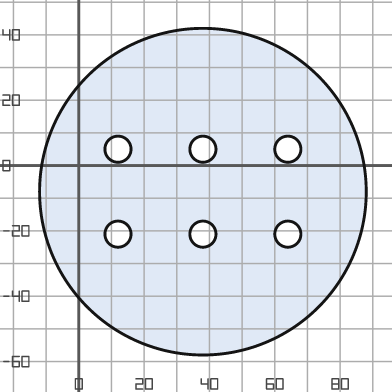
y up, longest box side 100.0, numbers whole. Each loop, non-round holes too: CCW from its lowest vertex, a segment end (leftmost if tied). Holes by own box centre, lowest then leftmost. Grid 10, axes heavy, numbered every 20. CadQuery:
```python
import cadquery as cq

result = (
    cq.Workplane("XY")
    .moveTo(38.0, -8.0)
    .circle(50.0)
    .moveTo(12.0, -21.0)
    .circle(4.0)
    .moveTo(38.0, -21.0)
    .circle(4.0)
    .moveTo(64.0, -21.0)
    .circle(4.0)
    .moveTo(12.0, 5.0)
    .circle(4.0)
    .moveTo(38.0, 5.0)
    .circle(4.0)
    .moveTo(64.0, 5.0)
    .circle(4.0)
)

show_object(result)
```